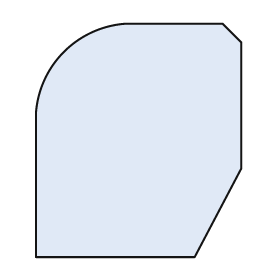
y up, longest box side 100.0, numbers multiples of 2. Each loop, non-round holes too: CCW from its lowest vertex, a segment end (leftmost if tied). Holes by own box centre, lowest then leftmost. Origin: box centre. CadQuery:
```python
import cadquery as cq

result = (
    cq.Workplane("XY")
    .moveTo(-44.0, -50.0)
    .lineTo(24.0, -50.0)
    .lineTo(44.0, -12.0)
    .lineTo(44.0, 42.0)
    .lineTo(36.0, 50.0)
    .lineTo(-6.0, 50.0)
    .threePointArc((-32.0, 38.0), (-44.0, 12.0))
    .close()
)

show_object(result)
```